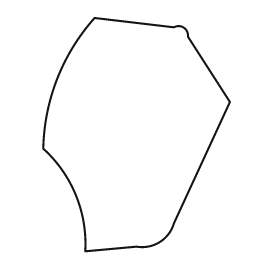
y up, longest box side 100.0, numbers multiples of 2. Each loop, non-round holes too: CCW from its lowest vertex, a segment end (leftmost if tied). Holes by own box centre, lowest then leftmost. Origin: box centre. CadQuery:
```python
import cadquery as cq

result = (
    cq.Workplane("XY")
    .moveTo(-22.0, -50.0)
    .lineTo(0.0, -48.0)
    .threePointArc((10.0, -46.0), (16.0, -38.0))
    .lineTo(40.0, 14.0)
    .lineTo(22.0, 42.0)
    .threePointArc((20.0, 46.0), (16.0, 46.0))
    .lineTo(-18.0, 50.0)
    .threePointArc((-34.0, 24.0), (-40.0, -6.0))
    .threePointArc((-26.0, -26.0), (-22.0, -50.0))
    .close()
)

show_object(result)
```